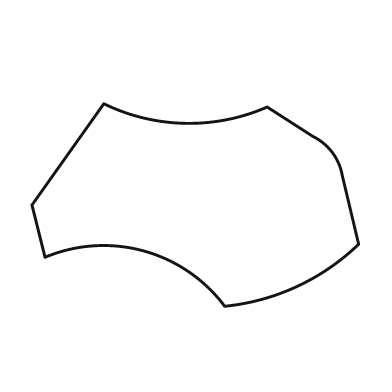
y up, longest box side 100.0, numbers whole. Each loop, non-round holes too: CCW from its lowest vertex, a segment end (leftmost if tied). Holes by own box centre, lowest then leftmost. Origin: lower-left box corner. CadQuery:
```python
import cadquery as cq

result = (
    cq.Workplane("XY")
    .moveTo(59.0, 0.0)
    .threePointArc((81.0, 6.0), (100.0, 19.0))
    .lineTo(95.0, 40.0)
    .threePointArc((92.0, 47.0), (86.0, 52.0))
    .lineTo(72.0, 61.0)
    .threePointArc((47.0, 56.0), (22.0, 62.0))
    .lineTo(0.0, 31.0)
    .lineTo(4.0, 15.0)
    .threePointArc((34.0, 17.0), (59.0, 0.0))
    .close()
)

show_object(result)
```